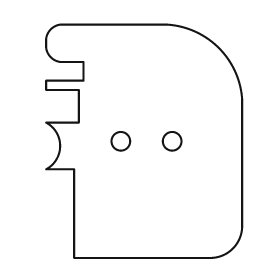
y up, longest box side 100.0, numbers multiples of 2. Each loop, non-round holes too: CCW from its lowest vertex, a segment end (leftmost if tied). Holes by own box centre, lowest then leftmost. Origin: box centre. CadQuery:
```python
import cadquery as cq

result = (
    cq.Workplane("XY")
    .moveTo(-30.0, -50.0)
    .lineTo(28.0, -50.0)
    .threePointArc((38.0, -46.0), (42.0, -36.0))
    .lineTo(42.0, 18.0)
    .threePointArc((32.0, 40.0), (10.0, 50.0))
    .lineTo(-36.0, 50.0)
    .threePointArc((-40.0, 48.0), (-42.0, 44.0))
    .lineTo(-42.0, 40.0)
    .threePointArc((-40.0, 36.0), (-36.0, 34.0))
    .lineTo(-26.0, 34.0)
    .lineTo(-26.0, 26.0)
    .lineTo(-42.0, 26.0)
    .lineTo(-42.0, 22.0)
    .lineTo(-28.0, 22.0)
    .lineTo(-28.0, 8.0)
    .lineTo(-42.0, 8.0)
    .threePointArc((-36.0, -2.0), (-42.0, -12.0))
    .lineTo(-30.0, -12.0)
    .close()
    .moveTo(-10.0, 0.0)
    .circle(4.0)
    .moveTo(12.0, 0.0)
    .circle(4.0)
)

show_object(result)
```